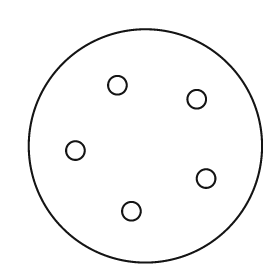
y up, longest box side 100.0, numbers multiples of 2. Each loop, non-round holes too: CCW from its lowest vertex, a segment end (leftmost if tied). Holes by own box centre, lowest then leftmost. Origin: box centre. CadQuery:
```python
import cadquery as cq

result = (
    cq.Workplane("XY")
    .moveTo(0.0, 0.0)
    .circle(50.0)
    .moveTo(-6.0, -28.0)
    .circle(4.0)
    .moveTo(26.0, -14.0)
    .circle(4.0)
    .moveTo(-30.0, -2.0)
    .circle(4.0)
    .moveTo(22.0, 20.0)
    .circle(4.0)
    .moveTo(-12.0, 26.0)
    .circle(4.0)
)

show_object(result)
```